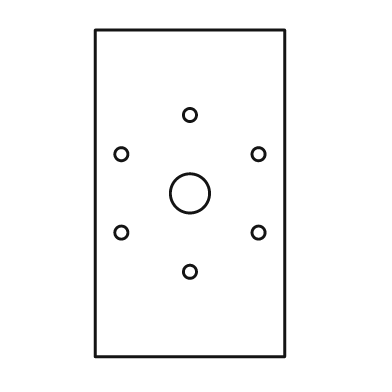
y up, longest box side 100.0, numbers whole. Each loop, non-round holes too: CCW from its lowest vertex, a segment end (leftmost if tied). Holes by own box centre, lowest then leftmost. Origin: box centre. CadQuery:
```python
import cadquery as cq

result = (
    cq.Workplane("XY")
    .moveTo(-29.0, -50.0)
    .lineTo(29.0, -50.0)
    .lineTo(29.0, 50.0)
    .lineTo(-29.0, 50.0)
    .close()
    .moveTo(0.0, -24.0)
    .circle(2.0)
    .moveTo(-21.0, -12.0)
    .circle(2.0)
    .moveTo(21.0, -12.0)
    .circle(2.0)
    .moveTo(0.0, 0.0)
    .circle(6.0)
    .moveTo(-21.0, 12.0)
    .circle(2.0)
    .moveTo(21.0, 12.0)
    .circle(2.0)
    .moveTo(0.0, 24.0)
    .circle(2.0)
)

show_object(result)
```